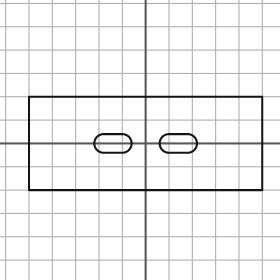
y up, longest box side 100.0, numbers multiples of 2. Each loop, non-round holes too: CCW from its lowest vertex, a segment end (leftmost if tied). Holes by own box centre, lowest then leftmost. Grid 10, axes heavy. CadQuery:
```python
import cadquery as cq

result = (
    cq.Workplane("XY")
    .moveTo(-50.0, -20.0)
    .lineTo(50.0, -20.0)
    .lineTo(50.0, 20.0)
    .lineTo(-50.0, 20.0)
    .close()
    .moveTo(-18.0, -4.0)
    .lineTo(-10.0, -4.0)
    .threePointArc((-6.0, 0.0), (-10.0, 4.0))
    .lineTo(-18.0, 4.0)
    .threePointArc((-22.0, 0.0), (-18.0, -4.0))
    .close()
    .moveTo(10.0, -4.0)
    .lineTo(18.0, -4.0)
    .threePointArc((22.0, 0.0), (18.0, 4.0))
    .lineTo(10.0, 4.0)
    .threePointArc((6.0, 0.0), (10.0, -4.0))
    .close()
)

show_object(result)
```